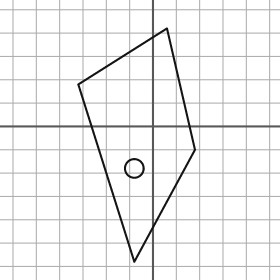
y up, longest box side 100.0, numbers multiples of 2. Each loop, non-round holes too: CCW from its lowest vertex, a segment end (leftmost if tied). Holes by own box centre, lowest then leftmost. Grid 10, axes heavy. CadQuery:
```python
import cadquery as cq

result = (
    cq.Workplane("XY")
    .moveTo(-8.0, -58.0)
    .lineTo(18.0, -10.0)
    .lineTo(6.0, 42.0)
    .lineTo(-32.0, 18.0)
    .close()
    .moveTo(-8.0, -18.0)
    .circle(4.0)
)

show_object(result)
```